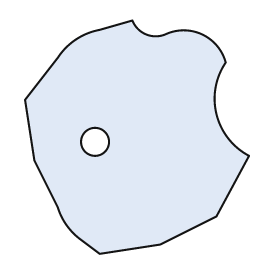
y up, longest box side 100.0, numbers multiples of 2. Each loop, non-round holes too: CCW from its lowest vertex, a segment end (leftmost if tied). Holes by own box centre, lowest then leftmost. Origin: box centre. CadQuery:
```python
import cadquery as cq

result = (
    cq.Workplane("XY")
    .moveTo(-16.0, -50.0)
    .lineTo(10.0, -46.0)
    .lineTo(34.0, -34.0)
    .lineTo(48.0, -8.0)
    .threePointArc((34.0, 10.0), (38.0, 32.0))
    .threePointArc((28.0, 44.0), (12.0, 44.0))
    .threePointArc((4.0, 44.0), (-2.0, 50.0))
    .lineTo(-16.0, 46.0)
    .threePointArc((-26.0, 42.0), (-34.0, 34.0))
    .lineTo(-48.0, 16.0)
    .lineTo(-44.0, -10.0)
    .lineTo(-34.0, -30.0)
    .threePointArc((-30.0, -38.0), (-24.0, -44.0))
    .close()
    .moveTo(-18.0, -2.0)
    .circle(6.0)
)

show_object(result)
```